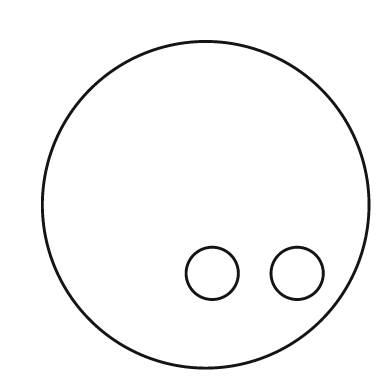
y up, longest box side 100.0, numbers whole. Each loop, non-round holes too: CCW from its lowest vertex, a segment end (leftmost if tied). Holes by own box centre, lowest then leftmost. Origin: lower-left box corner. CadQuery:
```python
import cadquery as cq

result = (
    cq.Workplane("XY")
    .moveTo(50.0, 50.0)
    .circle(50.0)
    .moveTo(52.0, 29.0)
    .circle(8.0)
    .moveTo(78.0, 29.0)
    .circle(8.0)
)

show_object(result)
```